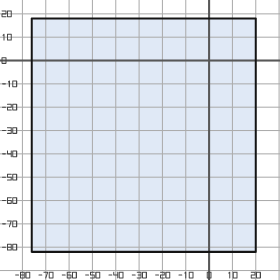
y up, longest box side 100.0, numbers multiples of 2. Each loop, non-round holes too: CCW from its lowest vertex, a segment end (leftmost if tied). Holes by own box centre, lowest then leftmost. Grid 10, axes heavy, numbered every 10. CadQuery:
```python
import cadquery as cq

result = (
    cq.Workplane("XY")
    .moveTo(-76.0, -82.0)
    .lineTo(20.0, -82.0)
    .lineTo(20.0, 18.0)
    .lineTo(-76.0, 18.0)
    .close()
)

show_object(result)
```